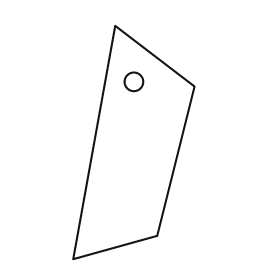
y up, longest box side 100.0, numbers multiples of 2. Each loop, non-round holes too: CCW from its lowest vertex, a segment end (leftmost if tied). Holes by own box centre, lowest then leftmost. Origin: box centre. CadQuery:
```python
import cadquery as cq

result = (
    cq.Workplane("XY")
    .moveTo(-26.0, -50.0)
    .lineTo(10.0, -40.0)
    .lineTo(26.0, 24.0)
    .lineTo(-8.0, 50.0)
    .close()
    .moveTo(0.0, 26.0)
    .circle(4.0)
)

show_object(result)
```